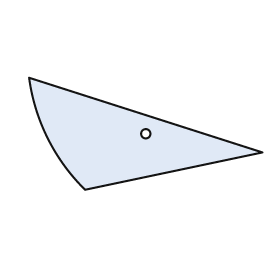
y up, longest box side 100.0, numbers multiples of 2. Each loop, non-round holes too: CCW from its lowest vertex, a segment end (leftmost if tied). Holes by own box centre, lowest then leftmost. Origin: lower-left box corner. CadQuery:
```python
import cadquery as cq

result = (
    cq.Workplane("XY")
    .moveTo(24.0, 0.0)
    .lineTo(100.0, 16.0)
    .lineTo(0.0, 48.0)
    .threePointArc((8.0, 22.0), (24.0, 0.0))
    .close()
    .moveTo(50.0, 24.0)
    .circle(2.0)
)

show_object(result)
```